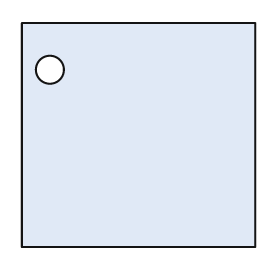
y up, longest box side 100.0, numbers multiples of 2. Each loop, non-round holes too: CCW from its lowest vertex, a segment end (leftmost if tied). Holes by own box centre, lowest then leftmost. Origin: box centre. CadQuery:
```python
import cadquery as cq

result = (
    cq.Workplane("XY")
    .moveTo(-50.0, -48.0)
    .lineTo(50.0, -48.0)
    .lineTo(50.0, 48.0)
    .lineTo(-50.0, 48.0)
    .close()
    .moveTo(-38.0, 28.0)
    .circle(6.0)
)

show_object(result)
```